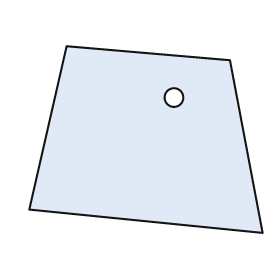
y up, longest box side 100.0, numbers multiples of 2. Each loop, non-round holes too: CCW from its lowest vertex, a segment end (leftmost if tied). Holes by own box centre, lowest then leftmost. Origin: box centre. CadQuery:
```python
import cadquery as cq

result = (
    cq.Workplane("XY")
    .moveTo(50.0, -40.0)
    .lineTo(36.0, 34.0)
    .lineTo(-34.0, 40.0)
    .lineTo(-50.0, -30.0)
    .close()
    .moveTo(12.0, 18.0)
    .circle(4.0)
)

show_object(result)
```